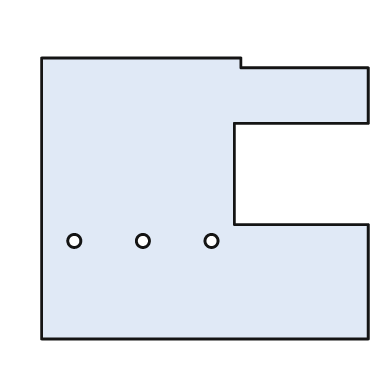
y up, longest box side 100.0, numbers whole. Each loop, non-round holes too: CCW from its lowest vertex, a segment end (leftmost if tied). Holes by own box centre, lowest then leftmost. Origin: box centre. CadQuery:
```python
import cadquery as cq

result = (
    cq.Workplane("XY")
    .moveTo(-50.0, -43.0)
    .lineTo(50.0, -43.0)
    .lineTo(50.0, -8.0)
    .lineTo(9.0, -8.0)
    .lineTo(9.0, 23.0)
    .lineTo(50.0, 23.0)
    .lineTo(50.0, 40.0)
    .lineTo(11.0, 40.0)
    .lineTo(11.0, 43.0)
    .lineTo(-50.0, 43.0)
    .close()
    .moveTo(-40.0, -13.0)
    .circle(2.0)
    .moveTo(-19.0, -13.0)
    .circle(2.0)
    .moveTo(2.0, -13.0)
    .circle(2.0)
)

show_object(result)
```